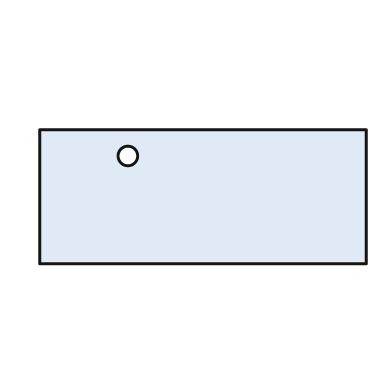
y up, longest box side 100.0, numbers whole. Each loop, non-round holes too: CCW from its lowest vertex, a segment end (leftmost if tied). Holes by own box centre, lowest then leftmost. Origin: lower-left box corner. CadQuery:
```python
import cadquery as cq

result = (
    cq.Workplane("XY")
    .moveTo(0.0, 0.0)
    .lineTo(100.0, 0.0)
    .lineTo(100.0, 41.0)
    .lineTo(0.0, 41.0)
    .close()
    .moveTo(27.0, 33.0)
    .circle(3.0)
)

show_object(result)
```